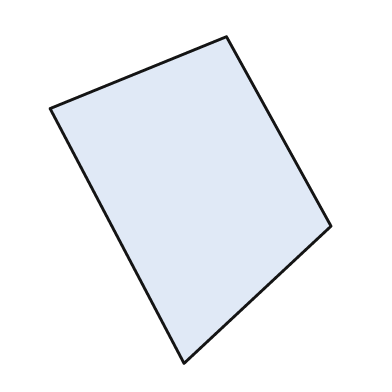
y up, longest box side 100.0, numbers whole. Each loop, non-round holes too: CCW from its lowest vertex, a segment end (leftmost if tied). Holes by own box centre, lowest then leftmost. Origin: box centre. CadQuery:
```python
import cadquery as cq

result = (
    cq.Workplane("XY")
    .moveTo(-2.0, -50.0)
    .lineTo(43.0, -8.0)
    .lineTo(11.0, 50.0)
    .lineTo(-43.0, 28.0)
    .close()
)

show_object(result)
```